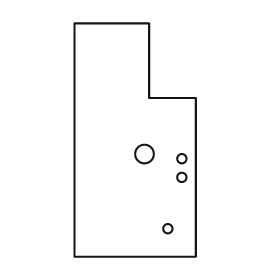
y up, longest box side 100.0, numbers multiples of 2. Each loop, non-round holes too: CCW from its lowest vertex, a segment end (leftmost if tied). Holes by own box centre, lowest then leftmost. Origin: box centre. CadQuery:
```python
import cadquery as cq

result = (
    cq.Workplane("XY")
    .moveTo(-26.0, -50.0)
    .lineTo(26.0, -50.0)
    .lineTo(26.0, 18.0)
    .lineTo(6.0, 18.0)
    .lineTo(6.0, 50.0)
    .lineTo(-26.0, 50.0)
    .close()
    .moveTo(14.0, -38.0)
    .circle(2.0)
    .moveTo(20.0, -16.0)
    .circle(2.0)
    .moveTo(20.0, -8.0)
    .circle(2.0)
    .moveTo(4.0, -6.0)
    .circle(4.0)
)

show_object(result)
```